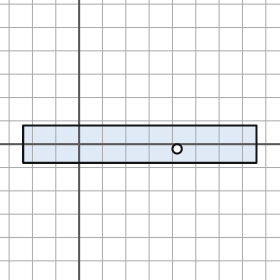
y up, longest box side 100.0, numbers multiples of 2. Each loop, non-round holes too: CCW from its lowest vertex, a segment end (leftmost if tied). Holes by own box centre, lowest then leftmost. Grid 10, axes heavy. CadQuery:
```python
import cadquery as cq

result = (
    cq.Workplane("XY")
    .moveTo(-24.0, -8.0)
    .lineTo(76.0, -8.0)
    .lineTo(76.0, 8.0)
    .lineTo(-24.0, 8.0)
    .close()
    .moveTo(42.0, -2.0)
    .circle(2.0)
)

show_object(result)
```